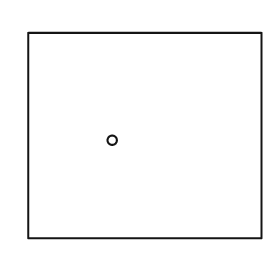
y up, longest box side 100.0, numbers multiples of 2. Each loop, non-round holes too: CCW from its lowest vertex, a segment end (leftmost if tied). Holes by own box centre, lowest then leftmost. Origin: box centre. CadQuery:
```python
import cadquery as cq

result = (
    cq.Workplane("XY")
    .moveTo(-50.0, -44.0)
    .lineTo(50.0, -44.0)
    .lineTo(50.0, 44.0)
    .lineTo(-50.0, 44.0)
    .close()
    .moveTo(-14.0, -2.0)
    .circle(2.0)
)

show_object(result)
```